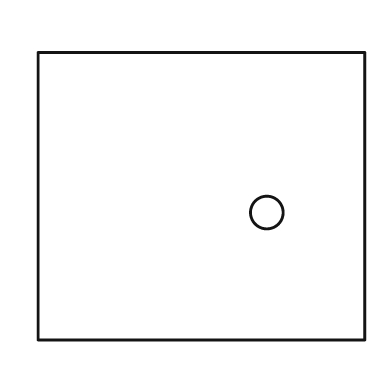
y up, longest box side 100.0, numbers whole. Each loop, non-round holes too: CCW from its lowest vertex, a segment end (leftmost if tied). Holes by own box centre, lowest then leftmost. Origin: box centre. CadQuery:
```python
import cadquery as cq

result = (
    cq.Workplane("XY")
    .moveTo(-50.0, -44.0)
    .lineTo(50.0, -44.0)
    .lineTo(50.0, 44.0)
    .lineTo(-50.0, 44.0)
    .close()
    .moveTo(20.0, -5.0)
    .circle(5.0)
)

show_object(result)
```